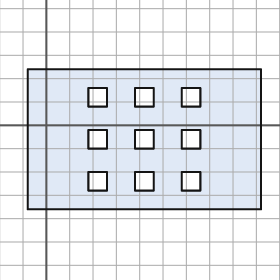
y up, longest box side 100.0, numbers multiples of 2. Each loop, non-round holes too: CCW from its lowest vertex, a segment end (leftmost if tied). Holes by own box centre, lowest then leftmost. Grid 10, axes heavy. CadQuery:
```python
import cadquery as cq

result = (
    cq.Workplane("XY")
    .moveTo(-8.0, -36.0)
    .lineTo(92.0, -36.0)
    .lineTo(92.0, 24.0)
    .lineTo(-8.0, 24.0)
    .close()
    .moveTo(18.0, -28.0)
    .lineTo(26.0, -28.0)
    .lineTo(26.0, -20.0)
    .lineTo(18.0, -20.0)
    .close()
    .moveTo(38.0, -28.0)
    .lineTo(46.0, -28.0)
    .lineTo(46.0, -20.0)
    .lineTo(38.0, -20.0)
    .close()
    .moveTo(58.0, -28.0)
    .lineTo(66.0, -28.0)
    .lineTo(66.0, -20.0)
    .lineTo(58.0, -20.0)
    .close()
    .moveTo(18.0, -10.0)
    .lineTo(26.0, -10.0)
    .lineTo(26.0, -2.0)
    .lineTo(18.0, -2.0)
    .close()
    .moveTo(38.0, -10.0)
    .lineTo(46.0, -10.0)
    .lineTo(46.0, -2.0)
    .lineTo(38.0, -2.0)
    .close()
    .moveTo(58.0, -10.0)
    .lineTo(66.0, -10.0)
    .lineTo(66.0, -2.0)
    .lineTo(58.0, -2.0)
    .close()
    .moveTo(18.0, 8.0)
    .lineTo(26.0, 8.0)
    .lineTo(26.0, 16.0)
    .lineTo(18.0, 16.0)
    .close()
    .moveTo(38.0, 8.0)
    .lineTo(46.0, 8.0)
    .lineTo(46.0, 16.0)
    .lineTo(38.0, 16.0)
    .close()
    .moveTo(58.0, 8.0)
    .lineTo(66.0, 8.0)
    .lineTo(66.0, 16.0)
    .lineTo(58.0, 16.0)
    .close()
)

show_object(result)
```